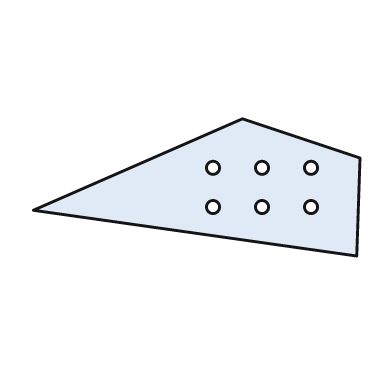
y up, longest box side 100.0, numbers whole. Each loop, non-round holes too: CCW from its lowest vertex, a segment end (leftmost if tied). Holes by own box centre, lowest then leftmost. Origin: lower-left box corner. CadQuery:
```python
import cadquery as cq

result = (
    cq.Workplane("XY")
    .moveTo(99.0, 0.0)
    .lineTo(100.0, 30.0)
    .lineTo(64.0, 42.0)
    .lineTo(0.0, 14.0)
    .close()
    .moveTo(55.0, 15.0)
    .circle(2.0)
    .moveTo(70.0, 15.0)
    .circle(2.0)
    .moveTo(85.0, 15.0)
    .circle(2.0)
    .moveTo(55.0, 27.0)
    .circle(2.0)
    .moveTo(70.0, 27.0)
    .circle(2.0)
    .moveTo(85.0, 27.0)
    .circle(2.0)
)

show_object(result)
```